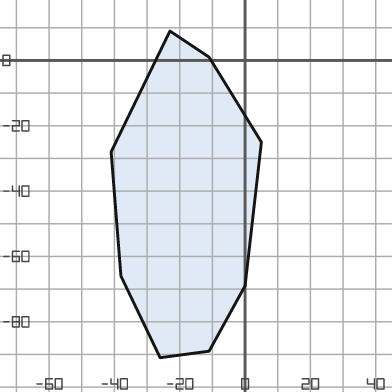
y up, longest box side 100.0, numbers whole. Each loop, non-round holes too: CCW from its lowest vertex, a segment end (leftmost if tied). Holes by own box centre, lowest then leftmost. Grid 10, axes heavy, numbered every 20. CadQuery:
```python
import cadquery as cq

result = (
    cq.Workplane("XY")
    .moveTo(-26.0, -91.0)
    .lineTo(-11.0, -89.0)
    .lineTo(0.0, -69.0)
    .lineTo(5.0, -25.0)
    .lineTo(-11.0, 1.0)
    .lineTo(-23.0, 9.0)
    .lineTo(-41.0, -28.0)
    .lineTo(-38.0, -66.0)
    .close()
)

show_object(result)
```